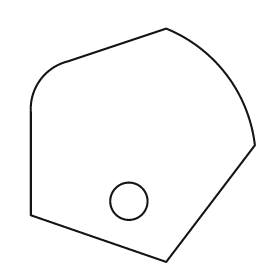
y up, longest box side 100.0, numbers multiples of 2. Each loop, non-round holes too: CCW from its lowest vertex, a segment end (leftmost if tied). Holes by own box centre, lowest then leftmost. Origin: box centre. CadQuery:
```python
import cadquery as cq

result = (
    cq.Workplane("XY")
    .moveTo(10.0, -50.0)
    .lineTo(48.0, 0.0)
    .threePointArc((36.0, 30.0), (10.0, 50.0))
    .lineTo(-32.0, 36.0)
    .threePointArc((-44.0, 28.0), (-48.0, 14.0))
    .lineTo(-48.0, -30.0)
    .close()
    .moveTo(-6.0, -24.0)
    .circle(8.0)
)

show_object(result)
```